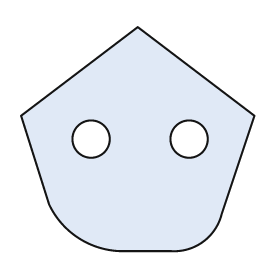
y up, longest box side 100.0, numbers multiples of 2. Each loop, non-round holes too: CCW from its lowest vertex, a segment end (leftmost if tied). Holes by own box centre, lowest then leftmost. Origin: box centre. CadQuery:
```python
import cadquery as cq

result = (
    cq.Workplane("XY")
    .moveTo(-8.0, -48.0)
    .lineTo(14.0, -48.0)
    .threePointArc((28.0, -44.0), (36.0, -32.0))
    .lineTo(50.0, 10.0)
    .lineTo(0.0, 48.0)
    .lineTo(-50.0, 10.0)
    .lineTo(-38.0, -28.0)
    .threePointArc((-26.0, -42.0), (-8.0, -48.0))
    .close()
    .moveTo(-20.0, 0.0)
    .circle(8.0)
    .moveTo(22.0, 0.0)
    .circle(8.0)
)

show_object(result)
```